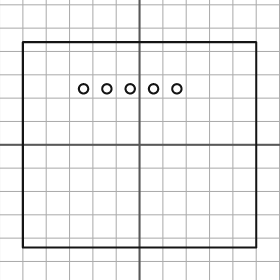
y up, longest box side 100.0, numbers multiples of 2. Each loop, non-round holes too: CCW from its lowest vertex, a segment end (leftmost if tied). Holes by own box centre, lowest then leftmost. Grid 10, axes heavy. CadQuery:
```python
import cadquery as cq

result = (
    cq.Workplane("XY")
    .moveTo(-50.0, -44.0)
    .lineTo(50.0, -44.0)
    .lineTo(50.0, 44.0)
    .lineTo(-50.0, 44.0)
    .close()
    .moveTo(-24.0, 24.0)
    .circle(2.0)
    .moveTo(-14.0, 24.0)
    .circle(2.0)
    .moveTo(-4.0, 24.0)
    .circle(2.0)
    .moveTo(6.0, 24.0)
    .circle(2.0)
    .moveTo(16.0, 24.0)
    .circle(2.0)
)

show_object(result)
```